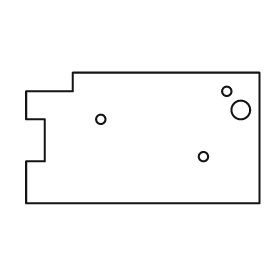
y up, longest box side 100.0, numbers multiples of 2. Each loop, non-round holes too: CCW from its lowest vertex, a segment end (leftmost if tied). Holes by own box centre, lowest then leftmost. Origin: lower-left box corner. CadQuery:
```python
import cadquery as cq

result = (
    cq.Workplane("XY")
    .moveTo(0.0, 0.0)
    .lineTo(100.0, 0.0)
    .lineTo(100.0, 56.0)
    .lineTo(20.0, 56.0)
    .lineTo(20.0, 48.0)
    .lineTo(0.0, 48.0)
    .lineTo(0.0, 36.0)
    .lineTo(8.0, 36.0)
    .lineTo(8.0, 18.0)
    .lineTo(0.0, 18.0)
    .close()
    .moveTo(76.0, 20.0)
    .circle(2.0)
    .moveTo(32.0, 36.0)
    .circle(2.0)
    .moveTo(92.0, 40.0)
    .circle(4.0)
    .moveTo(86.0, 48.0)
    .circle(2.0)
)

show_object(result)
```